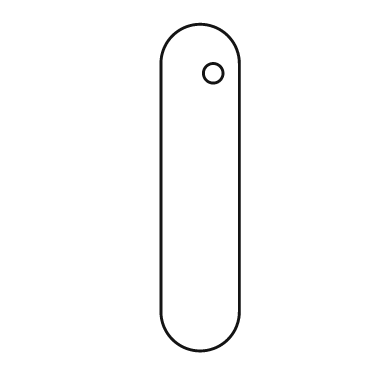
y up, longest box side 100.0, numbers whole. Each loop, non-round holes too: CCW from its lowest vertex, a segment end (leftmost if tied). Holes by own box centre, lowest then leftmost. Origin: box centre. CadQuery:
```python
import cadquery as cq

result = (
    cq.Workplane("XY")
    .moveTo(-12.0, -38.0)
    .threePointArc((0.0, -50.0), (12.0, -38.0))
    .lineTo(12.0, 38.0)
    .threePointArc((0.0, 50.0), (-12.0, 38.0))
    .close()
    .moveTo(4.0, 35.0)
    .circle(3.0)
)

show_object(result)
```